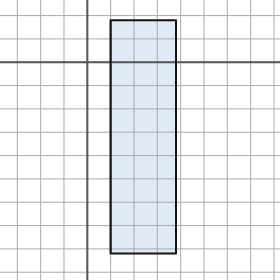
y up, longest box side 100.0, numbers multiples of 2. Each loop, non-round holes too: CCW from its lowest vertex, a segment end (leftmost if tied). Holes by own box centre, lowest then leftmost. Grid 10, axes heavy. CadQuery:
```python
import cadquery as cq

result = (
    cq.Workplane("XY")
    .moveTo(10.0, -82.0)
    .lineTo(38.0, -82.0)
    .lineTo(38.0, 18.0)
    .lineTo(10.0, 18.0)
    .close()
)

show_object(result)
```